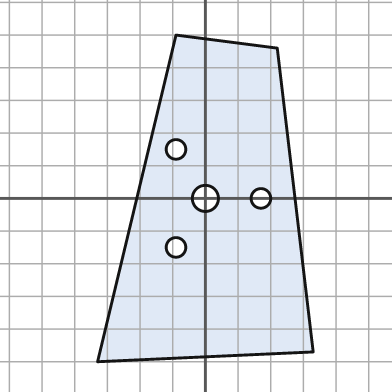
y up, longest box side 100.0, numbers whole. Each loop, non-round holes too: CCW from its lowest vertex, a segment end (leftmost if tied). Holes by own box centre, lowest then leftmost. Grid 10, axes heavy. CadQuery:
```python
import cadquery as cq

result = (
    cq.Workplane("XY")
    .moveTo(-33.0, -50.0)
    .lineTo(33.0, -47.0)
    .lineTo(22.0, 46.0)
    .lineTo(-9.0, 50.0)
    .close()
    .moveTo(-9.0, -15.0)
    .circle(3.0)
    .moveTo(0.0, 0.0)
    .circle(4.0)
    .moveTo(17.0, 0.0)
    .circle(3.0)
    .moveTo(-9.0, 15.0)
    .circle(3.0)
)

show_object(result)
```